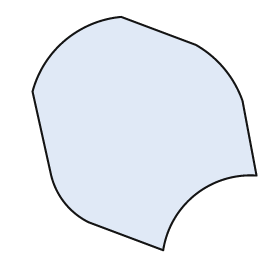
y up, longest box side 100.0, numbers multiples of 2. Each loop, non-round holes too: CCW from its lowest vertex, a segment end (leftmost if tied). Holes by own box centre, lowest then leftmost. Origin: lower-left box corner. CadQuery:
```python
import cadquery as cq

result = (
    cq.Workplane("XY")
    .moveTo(56.0, 0.0)
    .threePointArc((70.0, 24.0), (96.0, 32.0))
    .lineTo(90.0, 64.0)
    .threePointArc((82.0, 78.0), (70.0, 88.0))
    .lineTo(38.0, 100.0)
    .threePointArc((14.0, 90.0), (0.0, 68.0))
    .lineTo(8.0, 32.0)
    .threePointArc((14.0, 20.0), (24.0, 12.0))
    .close()
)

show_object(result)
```